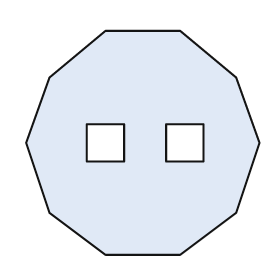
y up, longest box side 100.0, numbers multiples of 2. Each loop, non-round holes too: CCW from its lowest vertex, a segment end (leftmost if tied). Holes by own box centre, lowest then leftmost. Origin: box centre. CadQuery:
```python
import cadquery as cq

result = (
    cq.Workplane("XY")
    .moveTo(-16.0, -48.0)
    .lineTo(16.0, -48.0)
    .lineTo(40.0, -30.0)
    .lineTo(50.0, 0.0)
    .lineTo(40.0, 28.0)
    .lineTo(16.0, 48.0)
    .lineTo(-16.0, 48.0)
    .lineTo(-40.0, 28.0)
    .lineTo(-50.0, 0.0)
    .lineTo(-40.0, -30.0)
    .close()
    .moveTo(-24.0, -8.0)
    .lineTo(-8.0, -8.0)
    .lineTo(-8.0, 8.0)
    .lineTo(-24.0, 8.0)
    .close()
    .moveTo(10.0, -8.0)
    .lineTo(26.0, -8.0)
    .lineTo(26.0, 8.0)
    .lineTo(10.0, 8.0)
    .close()
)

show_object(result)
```